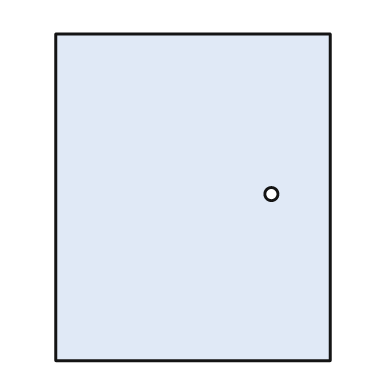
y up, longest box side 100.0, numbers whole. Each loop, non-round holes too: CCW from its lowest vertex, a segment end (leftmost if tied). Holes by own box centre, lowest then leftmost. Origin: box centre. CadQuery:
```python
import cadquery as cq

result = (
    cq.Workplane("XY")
    .moveTo(-42.0, -50.0)
    .lineTo(42.0, -50.0)
    .lineTo(42.0, 50.0)
    .lineTo(-42.0, 50.0)
    .close()
    .moveTo(24.0, 1.0)
    .circle(2.0)
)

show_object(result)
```